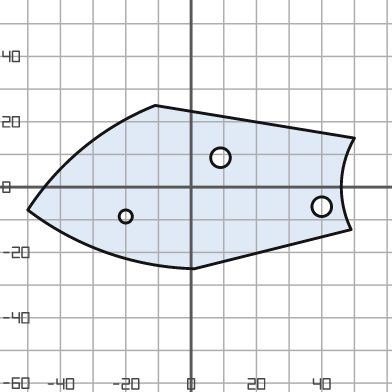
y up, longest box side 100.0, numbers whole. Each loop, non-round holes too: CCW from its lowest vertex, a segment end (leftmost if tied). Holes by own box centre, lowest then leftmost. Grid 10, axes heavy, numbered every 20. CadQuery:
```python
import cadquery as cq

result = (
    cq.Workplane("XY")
    .moveTo(1.0, -25.0)
    .lineTo(49.0, -13.0)
    .threePointArc((46.0, 1.0), (50.0, 15.0))
    .lineTo(-11.0, 25.0)
    .threePointArc((-33.0, 12.0), (-50.0, -7.0))
    .threePointArc((-26.0, -20.0), (1.0, -25.0))
    .close()
    .moveTo(-20.0, -9.0)
    .circle(2.0)
    .moveTo(40.0, -6.0)
    .circle(3.0)
    .moveTo(9.0, 9.0)
    .circle(3.0)
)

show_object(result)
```